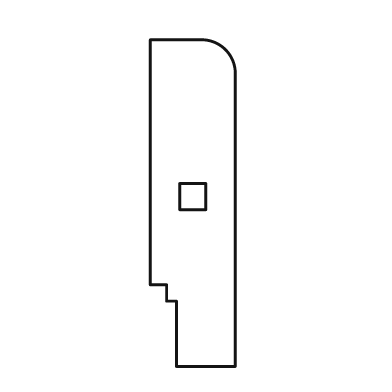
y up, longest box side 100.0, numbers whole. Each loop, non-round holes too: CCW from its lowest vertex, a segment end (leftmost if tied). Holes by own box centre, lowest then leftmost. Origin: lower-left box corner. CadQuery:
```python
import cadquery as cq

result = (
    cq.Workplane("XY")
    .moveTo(8.0, 0.0)
    .lineTo(26.0, 0.0)
    .lineTo(26.0, 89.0)
    .threePointArc((23.0, 97.0), (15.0, 100.0))
    .lineTo(0.0, 100.0)
    .lineTo(0.0, 25.0)
    .lineTo(5.0, 25.0)
    .lineTo(5.0, 20.0)
    .lineTo(8.0, 20.0)
    .close()
    .moveTo(9.0, 48.0)
    .lineTo(17.0, 48.0)
    .lineTo(17.0, 56.0)
    .lineTo(9.0, 56.0)
    .close()
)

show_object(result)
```